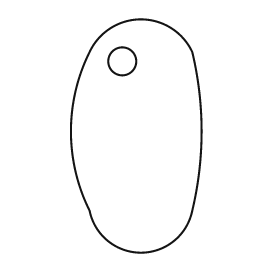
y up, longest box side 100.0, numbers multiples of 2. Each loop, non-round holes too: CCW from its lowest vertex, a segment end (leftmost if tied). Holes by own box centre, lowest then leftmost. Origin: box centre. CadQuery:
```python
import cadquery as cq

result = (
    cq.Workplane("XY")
    .moveTo(-20.0, -32.0)
    .threePointArc((2.0, -50.0), (24.0, -32.0))
    .threePointArc((28.0, 2.0), (24.0, 36.0))
    .threePointArc((2.0, 50.0), (-20.0, 36.0))
    .threePointArc((-28.0, 2.0), (-20.0, -32.0))
    .close()
    .moveTo(-6.0, 32.0)
    .circle(6.0)
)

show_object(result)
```